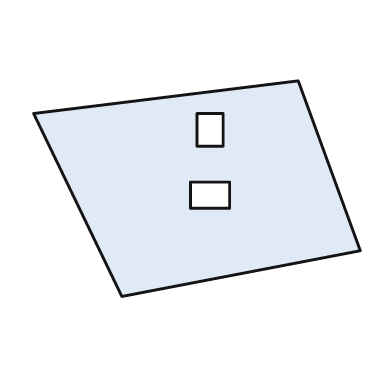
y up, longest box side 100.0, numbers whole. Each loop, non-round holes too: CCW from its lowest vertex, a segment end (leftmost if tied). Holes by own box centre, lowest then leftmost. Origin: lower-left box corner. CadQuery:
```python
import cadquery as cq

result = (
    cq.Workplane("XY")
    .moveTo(27.0, 0.0)
    .lineTo(100.0, 14.0)
    .lineTo(81.0, 66.0)
    .lineTo(0.0, 56.0)
    .close()
    .moveTo(48.0, 27.0)
    .lineTo(60.0, 27.0)
    .lineTo(60.0, 35.0)
    .lineTo(48.0, 35.0)
    .close()
    .moveTo(50.0, 46.0)
    .lineTo(58.0, 46.0)
    .lineTo(58.0, 56.0)
    .lineTo(50.0, 56.0)
    .close()
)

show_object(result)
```